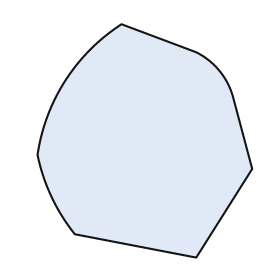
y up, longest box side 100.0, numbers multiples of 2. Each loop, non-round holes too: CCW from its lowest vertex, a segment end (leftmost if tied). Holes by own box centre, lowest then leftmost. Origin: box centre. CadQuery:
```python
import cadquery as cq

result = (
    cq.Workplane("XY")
    .moveTo(22.0, -50.0)
    .lineTo(46.0, -12.0)
    .lineTo(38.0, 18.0)
    .threePointArc((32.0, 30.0), (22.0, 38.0))
    .lineTo(-10.0, 50.0)
    .threePointArc((-34.0, 26.0), (-46.0, -6.0))
    .threePointArc((-40.0, -24.0), (-30.0, -40.0))
    .close()
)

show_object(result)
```